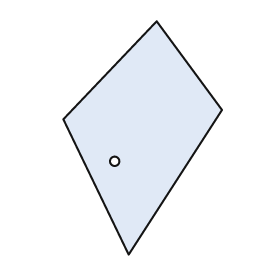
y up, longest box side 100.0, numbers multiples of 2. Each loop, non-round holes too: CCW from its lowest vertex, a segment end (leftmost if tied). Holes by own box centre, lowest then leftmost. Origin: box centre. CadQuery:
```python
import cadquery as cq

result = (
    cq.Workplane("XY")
    .moveTo(-6.0, -50.0)
    .lineTo(34.0, 12.0)
    .lineTo(6.0, 50.0)
    .lineTo(-34.0, 8.0)
    .close()
    .moveTo(-12.0, -10.0)
    .circle(2.0)
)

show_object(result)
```